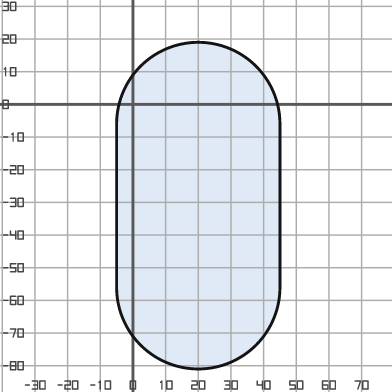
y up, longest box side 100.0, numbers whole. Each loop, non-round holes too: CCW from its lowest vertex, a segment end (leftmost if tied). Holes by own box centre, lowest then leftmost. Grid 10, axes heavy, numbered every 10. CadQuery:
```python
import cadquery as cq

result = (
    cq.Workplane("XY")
    .moveTo(-5.0, -56.0)
    .threePointArc((20.0, -81.0), (45.0, -56.0))
    .lineTo(45.0, -6.0)
    .threePointArc((20.0, 19.0), (-5.0, -6.0))
    .close()
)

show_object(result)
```